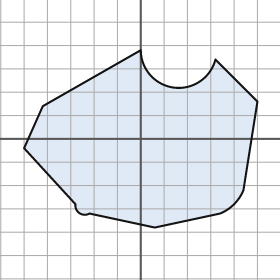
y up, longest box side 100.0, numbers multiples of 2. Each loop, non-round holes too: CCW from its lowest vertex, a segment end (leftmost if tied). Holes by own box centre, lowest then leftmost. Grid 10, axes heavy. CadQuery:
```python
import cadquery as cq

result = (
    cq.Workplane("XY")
    .moveTo(6.0, -38.0)
    .lineTo(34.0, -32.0)
    .threePointArc((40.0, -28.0), (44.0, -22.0))
    .lineTo(50.0, 16.0)
    .lineTo(32.0, 34.0)
    .threePointArc((14.0, 22.0), (0.0, 38.0))
    .lineTo(-42.0, 14.0)
    .lineTo(-50.0, -4.0)
    .lineTo(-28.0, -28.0)
    .threePointArc((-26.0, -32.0), (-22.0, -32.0))
    .close()
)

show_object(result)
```